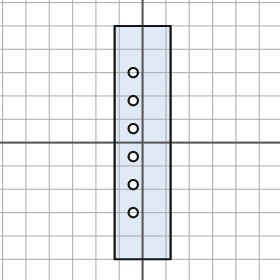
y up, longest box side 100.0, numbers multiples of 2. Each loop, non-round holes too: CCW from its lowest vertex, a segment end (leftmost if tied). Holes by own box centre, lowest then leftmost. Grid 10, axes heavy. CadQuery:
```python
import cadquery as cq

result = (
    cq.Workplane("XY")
    .moveTo(-12.0, -50.0)
    .lineTo(12.0, -50.0)
    .lineTo(12.0, 50.0)
    .lineTo(-12.0, 50.0)
    .close()
    .moveTo(-4.0, -30.0)
    .circle(2.0)
    .moveTo(-4.0, -18.0)
    .circle(2.0)
    .moveTo(-4.0, -6.0)
    .circle(2.0)
    .moveTo(-4.0, 6.0)
    .circle(2.0)
    .moveTo(-4.0, 18.0)
    .circle(2.0)
    .moveTo(-4.0, 30.0)
    .circle(2.0)
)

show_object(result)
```